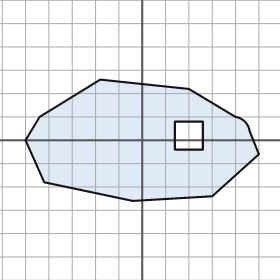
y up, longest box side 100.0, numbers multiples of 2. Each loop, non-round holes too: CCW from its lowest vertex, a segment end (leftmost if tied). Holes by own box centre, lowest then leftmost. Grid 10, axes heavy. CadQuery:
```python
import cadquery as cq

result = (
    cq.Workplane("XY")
    .moveTo(-4.0, -26.0)
    .lineTo(30.0, -24.0)
    .lineTo(50.0, -6.0)
    .lineTo(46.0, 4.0)
    .threePointArc((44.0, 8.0), (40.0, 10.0))
    .lineTo(20.0, 22.0)
    .lineTo(-18.0, 26.0)
    .lineTo(-44.0, 10.0)
    .lineTo(-50.0, 0.0)
    .lineTo(-42.0, -18.0)
    .close()
    .moveTo(14.0, -4.0)
    .lineTo(26.0, -4.0)
    .lineTo(26.0, 8.0)
    .lineTo(14.0, 8.0)
    .close()
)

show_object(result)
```